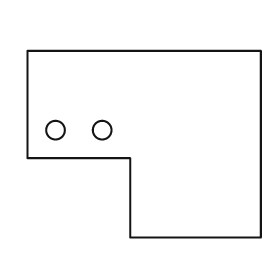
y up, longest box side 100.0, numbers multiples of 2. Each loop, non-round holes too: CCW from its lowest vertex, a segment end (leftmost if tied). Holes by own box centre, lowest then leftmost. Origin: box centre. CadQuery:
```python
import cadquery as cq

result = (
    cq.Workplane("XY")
    .moveTo(-6.0, -40.0)
    .lineTo(50.0, -40.0)
    .lineTo(50.0, 40.0)
    .lineTo(-50.0, 40.0)
    .lineTo(-50.0, -6.0)
    .lineTo(-6.0, -6.0)
    .close()
    .moveTo(-38.0, 6.0)
    .circle(4.0)
    .moveTo(-18.0, 6.0)
    .circle(4.0)
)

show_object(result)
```